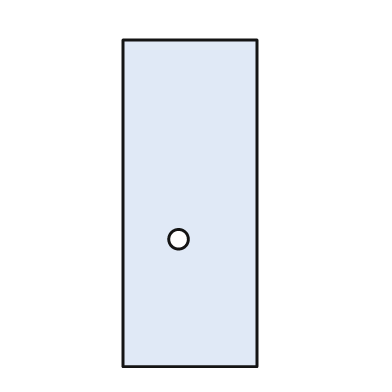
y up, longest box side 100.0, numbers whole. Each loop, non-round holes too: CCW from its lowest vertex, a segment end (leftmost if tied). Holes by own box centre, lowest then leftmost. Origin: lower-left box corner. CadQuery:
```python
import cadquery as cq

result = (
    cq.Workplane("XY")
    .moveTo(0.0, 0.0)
    .lineTo(41.0, 0.0)
    .lineTo(41.0, 100.0)
    .lineTo(0.0, 100.0)
    .close()
    .moveTo(17.0, 39.0)
    .circle(3.0)
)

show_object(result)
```